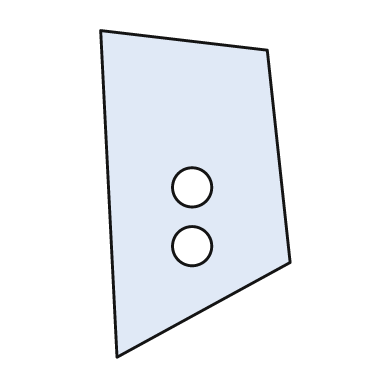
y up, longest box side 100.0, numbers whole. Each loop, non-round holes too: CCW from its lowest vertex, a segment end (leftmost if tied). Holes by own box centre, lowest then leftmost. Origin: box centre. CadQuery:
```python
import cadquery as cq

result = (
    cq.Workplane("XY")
    .moveTo(-24.0, -50.0)
    .lineTo(29.0, -21.0)
    .lineTo(22.0, 44.0)
    .lineTo(-29.0, 50.0)
    .close()
    .moveTo(-1.0, -16.0)
    .circle(6.0)
    .moveTo(-1.0, 2.0)
    .circle(6.0)
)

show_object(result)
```